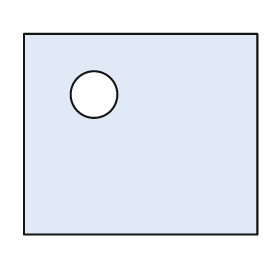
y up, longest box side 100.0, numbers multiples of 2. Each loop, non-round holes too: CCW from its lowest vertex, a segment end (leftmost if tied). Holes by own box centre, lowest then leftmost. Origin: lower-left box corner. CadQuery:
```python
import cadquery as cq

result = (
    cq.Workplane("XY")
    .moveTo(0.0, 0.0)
    .lineTo(100.0, 0.0)
    .lineTo(100.0, 86.0)
    .lineTo(0.0, 86.0)
    .close()
    .moveTo(30.0, 60.0)
    .circle(10.0)
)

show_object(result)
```